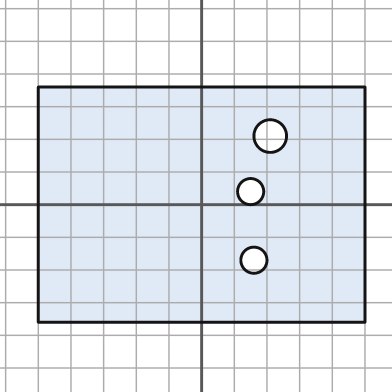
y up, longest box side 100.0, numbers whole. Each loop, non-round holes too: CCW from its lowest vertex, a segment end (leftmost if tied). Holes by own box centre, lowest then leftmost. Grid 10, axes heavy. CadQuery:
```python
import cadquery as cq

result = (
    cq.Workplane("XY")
    .moveTo(-50.0, -36.0)
    .lineTo(50.0, -36.0)
    .lineTo(50.0, 36.0)
    .lineTo(-50.0, 36.0)
    .close()
    .moveTo(16.0, -17.0)
    .circle(4.0)
    .moveTo(15.0, 4.0)
    .circle(4.0)
    .moveTo(21.0, 21.0)
    .circle(5.0)
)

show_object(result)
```